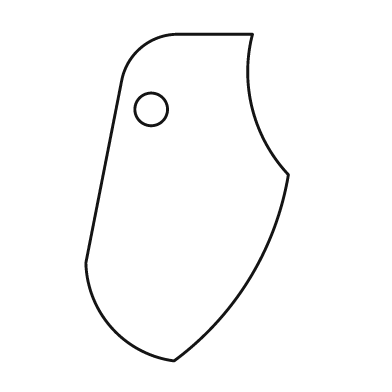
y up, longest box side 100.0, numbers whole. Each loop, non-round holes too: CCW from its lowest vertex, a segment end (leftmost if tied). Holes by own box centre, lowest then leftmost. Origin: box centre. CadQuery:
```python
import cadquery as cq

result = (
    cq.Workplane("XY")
    .moveTo(-4.0, -50.0)
    .threePointArc((19.0, -25.0), (31.0, 7.0))
    .threePointArc((20.0, 27.0), (20.0, 50.0))
    .lineTo(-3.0, 50.0)
    .threePointArc((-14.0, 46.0), (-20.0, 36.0))
    .lineTo(-31.0, -20.0)
    .threePointArc((-23.0, -40.0), (-4.0, -50.0))
    .close()
    .moveTo(-11.0, 27.0)
    .circle(5.0)
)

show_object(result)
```